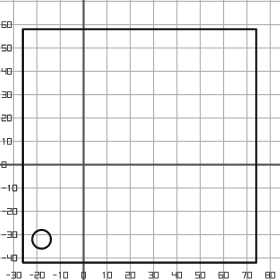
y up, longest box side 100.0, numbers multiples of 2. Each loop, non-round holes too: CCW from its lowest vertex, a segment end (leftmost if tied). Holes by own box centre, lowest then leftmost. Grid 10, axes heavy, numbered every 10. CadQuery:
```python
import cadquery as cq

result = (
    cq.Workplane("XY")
    .moveTo(-26.0, -42.0)
    .lineTo(74.0, -42.0)
    .lineTo(74.0, 58.0)
    .lineTo(-26.0, 58.0)
    .close()
    .moveTo(-18.0, -32.0)
    .circle(4.0)
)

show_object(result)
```